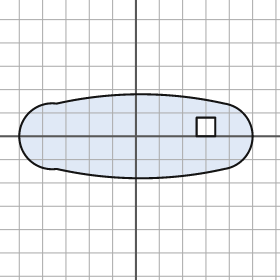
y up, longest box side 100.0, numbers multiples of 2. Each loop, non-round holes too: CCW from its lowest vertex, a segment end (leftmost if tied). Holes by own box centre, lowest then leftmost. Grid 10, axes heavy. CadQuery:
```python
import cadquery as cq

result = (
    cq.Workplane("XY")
    .moveTo(-34.0, -14.0)
    .threePointArc((2.0, -18.0), (38.0, -14.0))
    .threePointArc((50.0, 0.0), (38.0, 14.0))
    .threePointArc((2.0, 18.0), (-34.0, 14.0))
    .threePointArc((-50.0, 0.0), (-34.0, -14.0))
    .close()
    .moveTo(26.0, 0.0)
    .lineTo(34.0, 0.0)
    .lineTo(34.0, 8.0)
    .lineTo(26.0, 8.0)
    .close()
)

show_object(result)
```